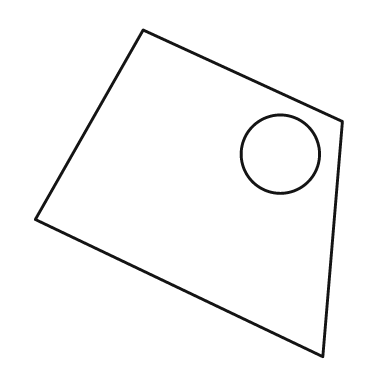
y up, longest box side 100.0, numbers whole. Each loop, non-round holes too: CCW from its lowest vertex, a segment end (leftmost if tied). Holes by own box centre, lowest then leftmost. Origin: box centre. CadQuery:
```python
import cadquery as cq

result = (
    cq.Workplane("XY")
    .moveTo(41.0, -50.0)
    .lineTo(47.0, 22.0)
    .lineTo(-14.0, 50.0)
    .lineTo(-47.0, -8.0)
    .close()
    .moveTo(28.0, 12.0)
    .circle(12.0)
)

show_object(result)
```